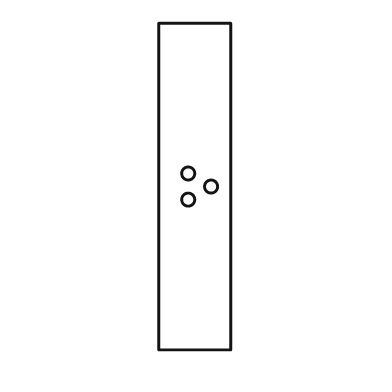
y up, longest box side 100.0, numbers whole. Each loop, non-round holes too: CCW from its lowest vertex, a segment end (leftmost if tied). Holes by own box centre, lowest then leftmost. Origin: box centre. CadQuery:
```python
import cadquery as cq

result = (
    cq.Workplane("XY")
    .moveTo(-11.0, -50.0)
    .lineTo(11.0, -50.0)
    .lineTo(11.0, 50.0)
    .lineTo(-11.0, 50.0)
    .close()
    .moveTo(-2.0, -4.0)
    .circle(2.0)
    .moveTo(5.0, 0.0)
    .circle(2.0)
    .moveTo(-2.0, 4.0)
    .circle(2.0)
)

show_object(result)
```